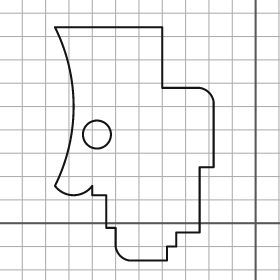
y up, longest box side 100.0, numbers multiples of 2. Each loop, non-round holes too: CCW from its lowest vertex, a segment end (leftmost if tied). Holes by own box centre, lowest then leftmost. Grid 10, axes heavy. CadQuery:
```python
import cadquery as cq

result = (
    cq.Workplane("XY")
    .moveTo(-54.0, -16.0)
    .lineTo(-38.0, -16.0)
    .lineTo(-38.0, -10.0)
    .lineTo(-34.0, -10.0)
    .lineTo(-34.0, -4.0)
    .lineTo(-24.0, -4.0)
    .lineTo(-24.0, 24.0)
    .lineTo(-18.0, 24.0)
    .lineTo(-18.0, 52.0)
    .threePointArc((-20.0, 56.0), (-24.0, 58.0))
    .lineTo(-40.0, 58.0)
    .lineTo(-40.0, 84.0)
    .lineTo(-86.0, 84.0)
    .threePointArc((-78.0, 50.0), (-86.0, 16.0))
    .threePointArc((-78.0, 12.0), (-70.0, 16.0))
    .lineTo(-70.0, 12.0)
    .lineTo(-64.0, 12.0)
    .lineTo(-64.0, -2.0)
    .lineTo(-60.0, -2.0)
    .lineTo(-60.0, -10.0)
    .threePointArc((-58.0, -14.0), (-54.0, -16.0))
    .close()
    .moveTo(-68.0, 38.0)
    .circle(6.0)
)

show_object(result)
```